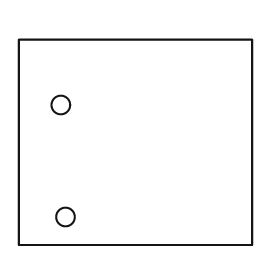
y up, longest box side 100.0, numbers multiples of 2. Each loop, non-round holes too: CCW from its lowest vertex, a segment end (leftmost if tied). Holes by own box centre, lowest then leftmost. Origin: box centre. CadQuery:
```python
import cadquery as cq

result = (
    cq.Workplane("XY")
    .moveTo(-50.0, -44.0)
    .lineTo(50.0, -44.0)
    .lineTo(50.0, 44.0)
    .lineTo(-50.0, 44.0)
    .close()
    .moveTo(-30.0, -32.0)
    .circle(4.0)
    .moveTo(-32.0, 16.0)
    .circle(4.0)
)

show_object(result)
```